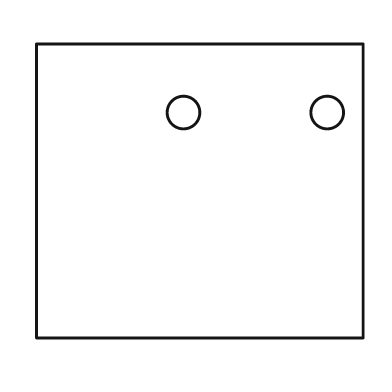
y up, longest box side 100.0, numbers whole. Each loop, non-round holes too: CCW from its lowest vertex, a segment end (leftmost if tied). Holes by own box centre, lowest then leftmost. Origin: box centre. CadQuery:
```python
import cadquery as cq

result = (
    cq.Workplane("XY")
    .moveTo(-50.0, -45.0)
    .lineTo(50.0, -45.0)
    .lineTo(50.0, 45.0)
    .lineTo(-50.0, 45.0)
    .close()
    .moveTo(-5.0, 24.0)
    .circle(5.0)
    .moveTo(39.0, 24.0)
    .circle(5.0)
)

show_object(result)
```